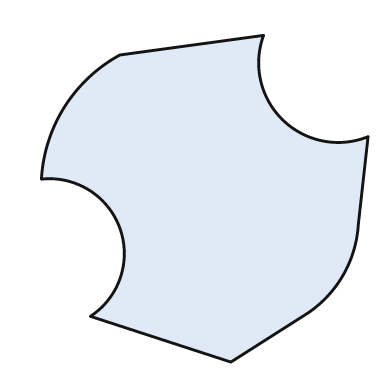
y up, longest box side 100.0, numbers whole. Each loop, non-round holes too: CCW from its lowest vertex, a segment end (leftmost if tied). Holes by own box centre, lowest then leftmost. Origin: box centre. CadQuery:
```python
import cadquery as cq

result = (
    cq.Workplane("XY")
    .moveTo(8.0, -50.0)
    .lineTo(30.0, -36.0)
    .threePointArc((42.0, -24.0), (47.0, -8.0))
    .lineTo(50.0, 19.0)
    .threePointArc((24.0, 24.0), (18.0, 50.0))
    .lineTo(-26.0, 44.0)
    .threePointArc((-43.0, 28.0), (-50.0, 6.0))
    .threePointArc((-26.0, -9.0), (-35.0, -36.0))
    .close()
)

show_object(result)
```